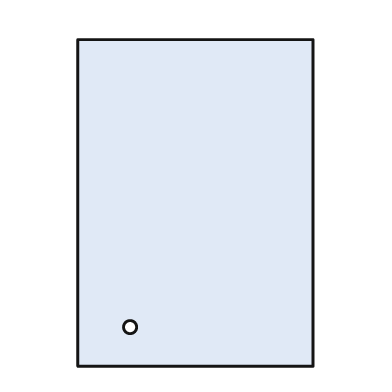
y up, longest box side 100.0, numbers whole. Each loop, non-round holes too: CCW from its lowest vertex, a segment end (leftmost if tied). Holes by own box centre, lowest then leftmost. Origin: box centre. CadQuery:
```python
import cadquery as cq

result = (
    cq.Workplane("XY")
    .moveTo(-36.0, -50.0)
    .lineTo(36.0, -50.0)
    .lineTo(36.0, 50.0)
    .lineTo(-36.0, 50.0)
    .close()
    .moveTo(-20.0, -38.0)
    .circle(2.0)
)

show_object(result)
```